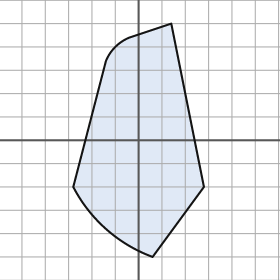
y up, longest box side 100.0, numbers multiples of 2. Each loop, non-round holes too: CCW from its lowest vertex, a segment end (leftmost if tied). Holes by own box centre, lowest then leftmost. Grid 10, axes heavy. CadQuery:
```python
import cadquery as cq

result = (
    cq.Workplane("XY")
    .moveTo(6.0, -50.0)
    .lineTo(28.0, -20.0)
    .lineTo(14.0, 50.0)
    .lineTo(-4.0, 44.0)
    .threePointArc((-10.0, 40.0), (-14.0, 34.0))
    .lineTo(-28.0, -20.0)
    .threePointArc((-14.0, -38.0), (6.0, -50.0))
    .close()
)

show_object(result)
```